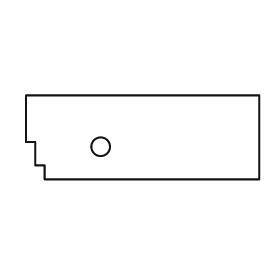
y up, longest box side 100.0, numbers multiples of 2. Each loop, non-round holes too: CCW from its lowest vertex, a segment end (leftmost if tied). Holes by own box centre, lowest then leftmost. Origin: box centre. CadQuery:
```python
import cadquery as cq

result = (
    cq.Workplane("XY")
    .moveTo(-42.0, -18.0)
    .lineTo(50.0, -18.0)
    .lineTo(50.0, 18.0)
    .lineTo(-50.0, 18.0)
    .lineTo(-50.0, -2.0)
    .lineTo(-46.0, -2.0)
    .lineTo(-46.0, -12.0)
    .lineTo(-42.0, -12.0)
    .close()
    .moveTo(-18.0, -4.0)
    .circle(4.0)
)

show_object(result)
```